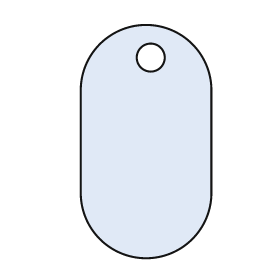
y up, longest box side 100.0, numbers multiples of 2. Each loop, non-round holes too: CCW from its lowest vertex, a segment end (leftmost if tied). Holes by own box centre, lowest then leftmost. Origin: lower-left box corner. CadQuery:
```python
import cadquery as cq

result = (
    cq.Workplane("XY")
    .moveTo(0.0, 28.0)
    .threePointArc((28.0, 0.0), (56.0, 28.0))
    .lineTo(56.0, 72.0)
    .threePointArc((28.0, 100.0), (0.0, 72.0))
    .close()
    .moveTo(30.0, 86.0)
    .circle(6.0)
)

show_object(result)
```